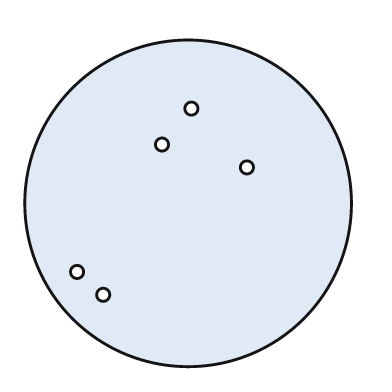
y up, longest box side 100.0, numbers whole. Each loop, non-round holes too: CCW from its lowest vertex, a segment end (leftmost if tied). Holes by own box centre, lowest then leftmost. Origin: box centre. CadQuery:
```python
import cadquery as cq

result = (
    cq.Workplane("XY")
    .moveTo(0.0, 0.0)
    .circle(50.0)
    .moveTo(-26.0, -28.0)
    .circle(2.0)
    .moveTo(-34.0, -21.0)
    .circle(2.0)
    .moveTo(18.0, 11.0)
    .circle(2.0)
    .moveTo(-8.0, 18.0)
    .circle(2.0)
    .moveTo(1.0, 29.0)
    .circle(2.0)
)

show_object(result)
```